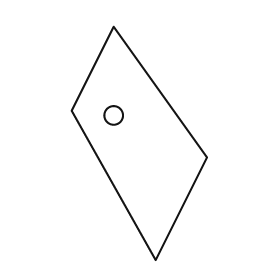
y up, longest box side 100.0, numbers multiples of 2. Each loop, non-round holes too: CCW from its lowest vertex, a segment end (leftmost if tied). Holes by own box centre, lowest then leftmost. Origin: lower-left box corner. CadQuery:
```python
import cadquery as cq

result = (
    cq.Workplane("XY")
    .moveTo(36.0, 0.0)
    .lineTo(58.0, 44.0)
    .lineTo(18.0, 100.0)
    .lineTo(0.0, 64.0)
    .close()
    .moveTo(18.0, 62.0)
    .circle(4.0)
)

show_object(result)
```